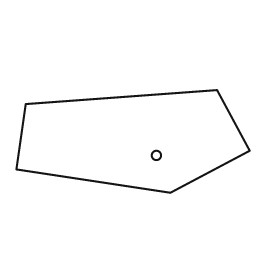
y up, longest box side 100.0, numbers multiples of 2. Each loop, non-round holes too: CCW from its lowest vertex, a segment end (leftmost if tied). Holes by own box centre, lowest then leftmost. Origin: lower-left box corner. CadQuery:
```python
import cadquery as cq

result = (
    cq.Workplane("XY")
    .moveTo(66.0, 0.0)
    .lineTo(100.0, 18.0)
    .lineTo(86.0, 44.0)
    .lineTo(4.0, 38.0)
    .lineTo(0.0, 10.0)
    .close()
    .moveTo(60.0, 16.0)
    .circle(2.0)
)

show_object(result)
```